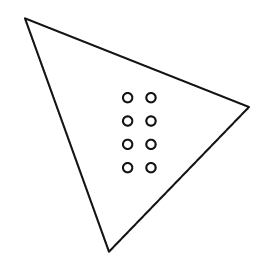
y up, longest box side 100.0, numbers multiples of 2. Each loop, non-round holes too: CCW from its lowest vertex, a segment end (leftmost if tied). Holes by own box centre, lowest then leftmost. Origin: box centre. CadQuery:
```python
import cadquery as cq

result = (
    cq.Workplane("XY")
    .moveTo(-12.0, -50.0)
    .lineTo(48.0, 12.0)
    .lineTo(-48.0, 50.0)
    .close()
    .moveTo(-4.0, -14.0)
    .circle(2.0)
    .moveTo(6.0, -14.0)
    .circle(2.0)
    .moveTo(-4.0, -4.0)
    .circle(2.0)
    .moveTo(6.0, -4.0)
    .circle(2.0)
    .moveTo(-4.0, 6.0)
    .circle(2.0)
    .moveTo(6.0, 6.0)
    .circle(2.0)
    .moveTo(-4.0, 16.0)
    .circle(2.0)
    .moveTo(6.0, 16.0)
    .circle(2.0)
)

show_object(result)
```